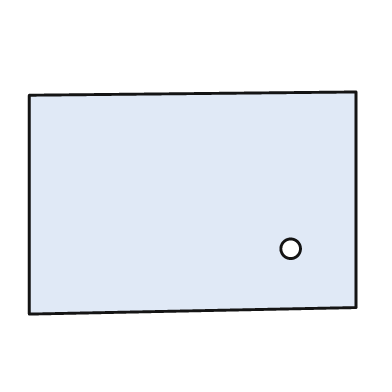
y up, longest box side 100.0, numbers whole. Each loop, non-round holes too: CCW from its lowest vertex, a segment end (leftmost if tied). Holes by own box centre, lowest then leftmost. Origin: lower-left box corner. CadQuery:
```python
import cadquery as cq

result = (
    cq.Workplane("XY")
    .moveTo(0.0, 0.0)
    .lineTo(100.0, 2.0)
    .lineTo(100.0, 68.0)
    .lineTo(0.0, 67.0)
    .close()
    .moveTo(80.0, 20.0)
    .circle(3.0)
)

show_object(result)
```